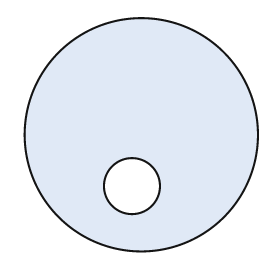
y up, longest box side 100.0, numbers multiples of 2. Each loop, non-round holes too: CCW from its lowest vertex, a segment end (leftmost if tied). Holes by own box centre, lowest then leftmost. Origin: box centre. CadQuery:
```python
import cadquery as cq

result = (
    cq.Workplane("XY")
    .moveTo(0.0, 0.0)
    .circle(50.0)
    .moveTo(-4.0, -22.0)
    .circle(12.0)
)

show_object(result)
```